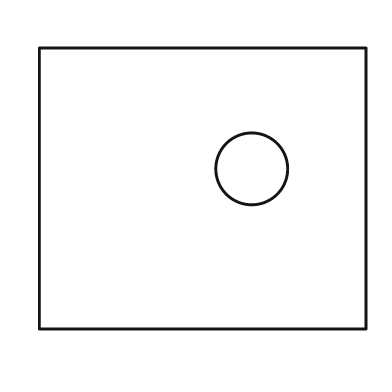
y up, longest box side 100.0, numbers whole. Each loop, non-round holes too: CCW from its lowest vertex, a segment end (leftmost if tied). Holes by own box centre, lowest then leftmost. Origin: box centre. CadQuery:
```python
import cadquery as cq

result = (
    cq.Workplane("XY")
    .moveTo(-50.0, -43.0)
    .lineTo(50.0, -43.0)
    .lineTo(50.0, 43.0)
    .lineTo(-50.0, 43.0)
    .close()
    .moveTo(15.0, 6.0)
    .circle(11.0)
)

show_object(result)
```